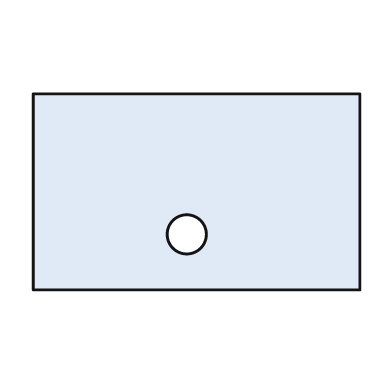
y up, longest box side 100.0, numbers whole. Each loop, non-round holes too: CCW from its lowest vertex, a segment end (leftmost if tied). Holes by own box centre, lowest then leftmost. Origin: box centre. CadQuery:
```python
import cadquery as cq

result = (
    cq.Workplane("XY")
    .moveTo(-50.0, -30.0)
    .lineTo(50.0, -30.0)
    .lineTo(50.0, 30.0)
    .lineTo(-50.0, 30.0)
    .close()
    .moveTo(-3.0, -13.0)
    .circle(6.0)
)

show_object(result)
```